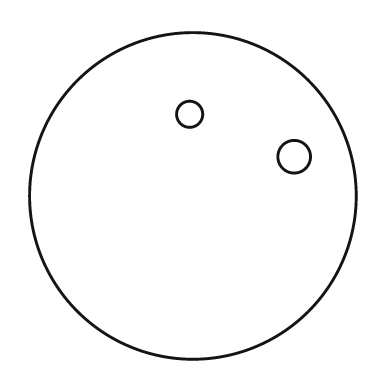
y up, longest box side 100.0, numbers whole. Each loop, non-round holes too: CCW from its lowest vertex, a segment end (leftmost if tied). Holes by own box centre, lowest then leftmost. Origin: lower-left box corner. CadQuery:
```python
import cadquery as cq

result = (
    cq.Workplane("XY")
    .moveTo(50.0, 50.0)
    .circle(50.0)
    .moveTo(81.0, 62.0)
    .circle(5.0)
    .moveTo(49.0, 75.0)
    .circle(4.0)
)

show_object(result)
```